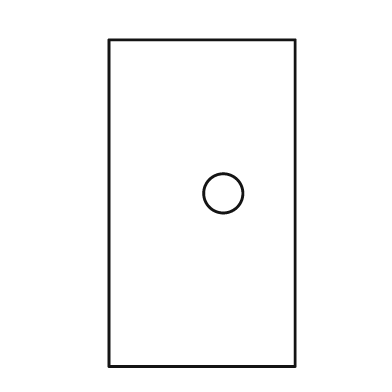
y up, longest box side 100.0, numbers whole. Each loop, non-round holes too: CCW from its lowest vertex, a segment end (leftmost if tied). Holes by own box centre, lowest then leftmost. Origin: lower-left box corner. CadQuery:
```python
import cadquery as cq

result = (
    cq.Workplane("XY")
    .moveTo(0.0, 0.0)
    .lineTo(57.0, 0.0)
    .lineTo(57.0, 100.0)
    .lineTo(0.0, 100.0)
    .close()
    .moveTo(35.0, 53.0)
    .circle(6.0)
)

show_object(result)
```